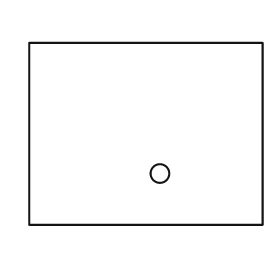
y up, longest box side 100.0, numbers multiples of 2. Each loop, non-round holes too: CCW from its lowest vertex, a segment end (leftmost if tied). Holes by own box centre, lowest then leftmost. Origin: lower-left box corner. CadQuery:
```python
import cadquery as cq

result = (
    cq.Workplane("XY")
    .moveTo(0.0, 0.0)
    .lineTo(100.0, 0.0)
    .lineTo(100.0, 78.0)
    .lineTo(0.0, 78.0)
    .close()
    .moveTo(56.0, 22.0)
    .circle(4.0)
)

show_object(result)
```